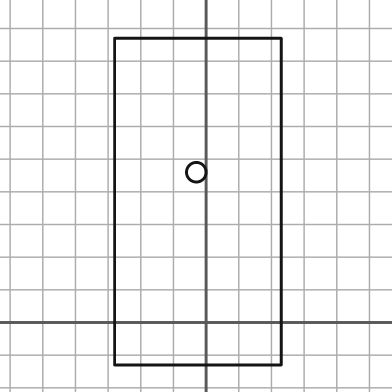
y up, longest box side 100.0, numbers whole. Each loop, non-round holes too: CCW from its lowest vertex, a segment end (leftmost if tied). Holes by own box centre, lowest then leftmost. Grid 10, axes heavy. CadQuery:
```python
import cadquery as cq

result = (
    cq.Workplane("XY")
    .moveTo(-28.0, -13.0)
    .lineTo(23.0, -13.0)
    .lineTo(23.0, 87.0)
    .lineTo(-28.0, 87.0)
    .close()
    .moveTo(-3.0, 46.0)
    .circle(3.0)
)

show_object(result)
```